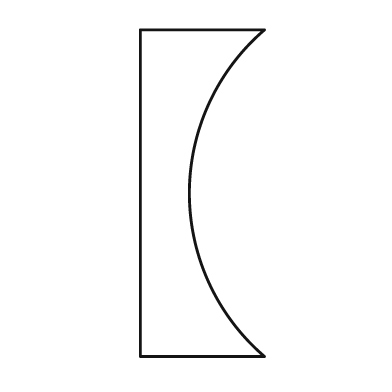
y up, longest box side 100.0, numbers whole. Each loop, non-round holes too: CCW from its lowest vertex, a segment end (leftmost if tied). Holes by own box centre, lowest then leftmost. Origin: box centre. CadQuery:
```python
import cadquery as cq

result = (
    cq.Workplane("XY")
    .moveTo(-19.0, -50.0)
    .lineTo(19.0, -50.0)
    .threePointArc((-4.0, 0.0), (19.0, 50.0))
    .lineTo(-19.0, 50.0)
    .close()
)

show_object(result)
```